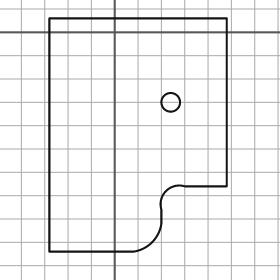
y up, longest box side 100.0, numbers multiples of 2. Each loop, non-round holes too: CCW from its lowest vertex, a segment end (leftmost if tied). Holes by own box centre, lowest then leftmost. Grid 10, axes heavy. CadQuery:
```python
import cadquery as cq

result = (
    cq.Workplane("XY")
    .moveTo(-28.0, -94.0)
    .lineTo(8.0, -94.0)
    .threePointArc((16.0, -90.0), (20.0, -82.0))
    .lineTo(20.0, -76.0)
    .threePointArc((22.0, -68.0), (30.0, -66.0))
    .lineTo(48.0, -66.0)
    .lineTo(48.0, 6.0)
    .lineTo(-28.0, 6.0)
    .close()
    .moveTo(24.0, -30.0)
    .circle(4.0)
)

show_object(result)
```